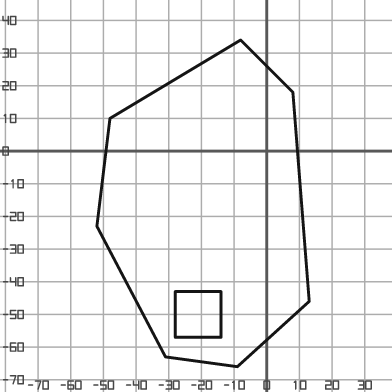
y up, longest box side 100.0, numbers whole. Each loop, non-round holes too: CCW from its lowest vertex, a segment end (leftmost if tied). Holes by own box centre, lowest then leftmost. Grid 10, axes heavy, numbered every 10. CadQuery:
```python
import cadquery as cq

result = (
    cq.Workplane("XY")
    .moveTo(-9.0, -66.0)
    .lineTo(13.0, -46.0)
    .lineTo(8.0, 18.0)
    .lineTo(-8.0, 34.0)
    .lineTo(-48.0, 10.0)
    .lineTo(-52.0, -23.0)
    .lineTo(-31.0, -63.0)
    .close()
    .moveTo(-28.0, -57.0)
    .lineTo(-14.0, -57.0)
    .lineTo(-14.0, -43.0)
    .lineTo(-28.0, -43.0)
    .close()
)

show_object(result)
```